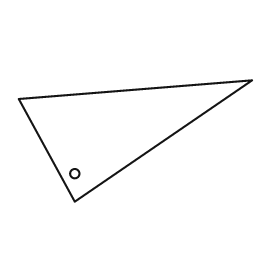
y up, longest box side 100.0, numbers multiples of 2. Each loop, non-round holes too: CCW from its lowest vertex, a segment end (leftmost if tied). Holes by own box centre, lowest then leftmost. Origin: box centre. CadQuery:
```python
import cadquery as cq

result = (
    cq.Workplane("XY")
    .moveTo(-26.0, -26.0)
    .lineTo(50.0, 26.0)
    .lineTo(-50.0, 18.0)
    .close()
    .moveTo(-26.0, -14.0)
    .circle(2.0)
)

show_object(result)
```